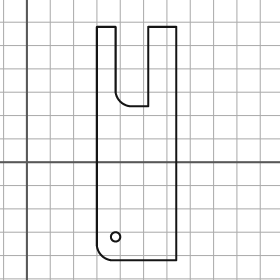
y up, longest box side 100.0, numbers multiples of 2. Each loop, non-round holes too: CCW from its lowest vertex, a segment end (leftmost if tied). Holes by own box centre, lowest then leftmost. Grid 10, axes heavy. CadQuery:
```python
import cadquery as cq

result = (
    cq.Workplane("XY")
    .moveTo(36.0, -42.0)
    .lineTo(64.0, -42.0)
    .lineTo(64.0, 58.0)
    .lineTo(52.0, 58.0)
    .lineTo(52.0, 24.0)
    .lineTo(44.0, 24.0)
    .threePointArc((40.0, 26.0), (38.0, 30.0))
    .lineTo(38.0, 58.0)
    .lineTo(30.0, 58.0)
    .lineTo(30.0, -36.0)
    .threePointArc((32.0, -40.0), (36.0, -42.0))
    .close()
    .moveTo(38.0, -32.0)
    .circle(2.0)
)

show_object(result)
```